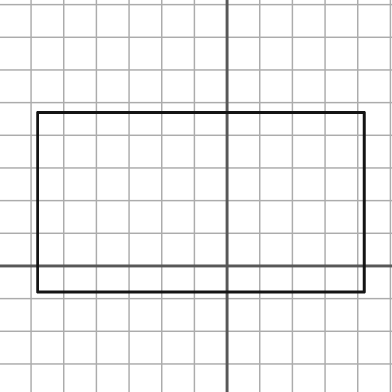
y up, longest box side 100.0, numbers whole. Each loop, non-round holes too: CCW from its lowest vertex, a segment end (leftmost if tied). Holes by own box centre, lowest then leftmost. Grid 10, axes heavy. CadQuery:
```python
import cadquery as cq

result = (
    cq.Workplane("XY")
    .moveTo(-58.0, -8.0)
    .lineTo(42.0, -8.0)
    .lineTo(42.0, 47.0)
    .lineTo(-58.0, 47.0)
    .close()
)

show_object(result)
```